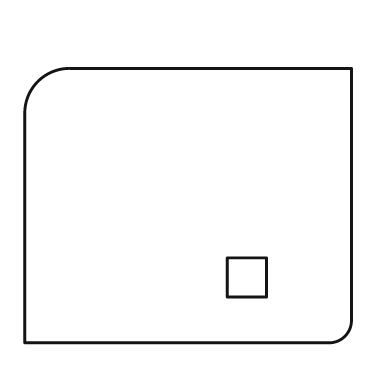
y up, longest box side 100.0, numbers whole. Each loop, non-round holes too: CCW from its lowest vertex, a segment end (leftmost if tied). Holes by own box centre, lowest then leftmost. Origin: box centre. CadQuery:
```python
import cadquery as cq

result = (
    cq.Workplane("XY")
    .moveTo(-50.0, -42.0)
    .lineTo(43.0, -42.0)
    .threePointArc((48.0, -40.0), (50.0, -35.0))
    .lineTo(50.0, 42.0)
    .lineTo(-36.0, 42.0)
    .threePointArc((-46.0, 38.0), (-50.0, 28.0))
    .close()
    .moveTo(12.0, -28.0)
    .lineTo(24.0, -28.0)
    .lineTo(24.0, -16.0)
    .lineTo(12.0, -16.0)
    .close()
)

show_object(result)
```